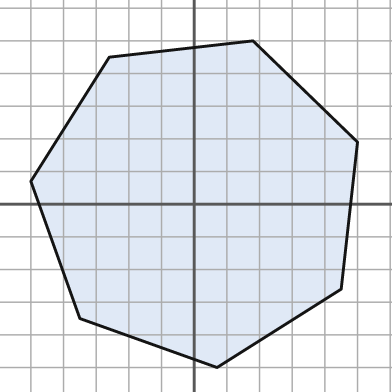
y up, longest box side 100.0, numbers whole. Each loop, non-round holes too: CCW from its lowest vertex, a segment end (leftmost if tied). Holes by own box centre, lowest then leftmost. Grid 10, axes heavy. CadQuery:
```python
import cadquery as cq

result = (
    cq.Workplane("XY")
    .moveTo(7.0, -50.0)
    .lineTo(45.0, -26.0)
    .lineTo(50.0, 19.0)
    .lineTo(18.0, 50.0)
    .lineTo(-26.0, 45.0)
    .lineTo(-50.0, 7.0)
    .lineTo(-35.0, -35.0)
    .close()
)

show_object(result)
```